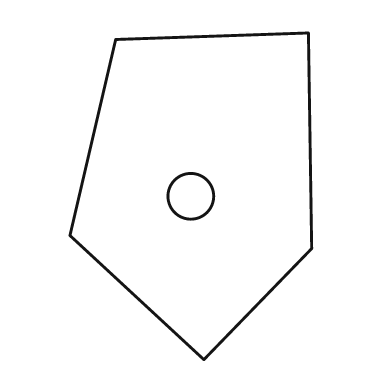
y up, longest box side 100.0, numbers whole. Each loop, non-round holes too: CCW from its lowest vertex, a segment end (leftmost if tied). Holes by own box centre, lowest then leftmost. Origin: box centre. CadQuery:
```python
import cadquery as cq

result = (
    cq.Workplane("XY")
    .moveTo(4.0, -50.0)
    .lineTo(37.0, -16.0)
    .lineTo(36.0, 50.0)
    .lineTo(-23.0, 48.0)
    .lineTo(-37.0, -12.0)
    .close()
    .moveTo(0.0, 0.0)
    .circle(7.0)
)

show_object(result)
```